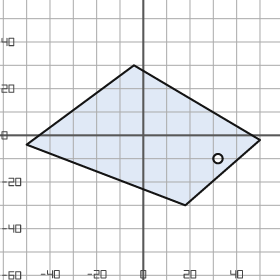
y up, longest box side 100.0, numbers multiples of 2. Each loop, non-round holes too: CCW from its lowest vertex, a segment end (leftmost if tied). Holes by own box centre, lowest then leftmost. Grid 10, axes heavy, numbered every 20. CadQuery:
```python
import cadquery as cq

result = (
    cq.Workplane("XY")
    .moveTo(18.0, -30.0)
    .lineTo(50.0, -2.0)
    .lineTo(-4.0, 30.0)
    .lineTo(-50.0, -4.0)
    .close()
    .moveTo(32.0, -10.0)
    .circle(2.0)
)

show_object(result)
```